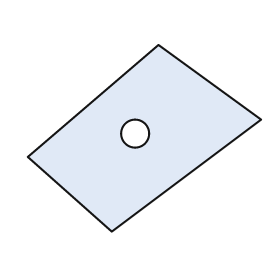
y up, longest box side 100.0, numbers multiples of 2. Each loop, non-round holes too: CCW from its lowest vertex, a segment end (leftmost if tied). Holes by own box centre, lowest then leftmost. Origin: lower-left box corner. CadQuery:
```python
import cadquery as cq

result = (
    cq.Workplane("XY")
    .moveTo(36.0, 0.0)
    .lineTo(100.0, 48.0)
    .lineTo(56.0, 80.0)
    .lineTo(0.0, 32.0)
    .close()
    .moveTo(46.0, 42.0)
    .circle(6.0)
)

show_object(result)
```